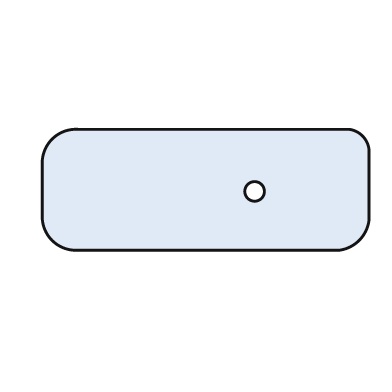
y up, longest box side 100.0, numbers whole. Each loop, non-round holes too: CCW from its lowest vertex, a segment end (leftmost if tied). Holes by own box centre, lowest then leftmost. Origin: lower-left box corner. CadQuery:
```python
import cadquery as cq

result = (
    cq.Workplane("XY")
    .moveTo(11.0, 0.0)
    .lineTo(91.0, 0.0)
    .threePointArc((97.0, 3.0), (100.0, 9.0))
    .lineTo(100.0, 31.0)
    .threePointArc((98.0, 35.0), (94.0, 37.0))
    .lineTo(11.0, 37.0)
    .threePointArc((3.0, 34.0), (0.0, 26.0))
    .lineTo(0.0, 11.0)
    .threePointArc((3.0, 3.0), (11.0, 0.0))
    .close()
    .moveTo(65.0, 18.0)
    .circle(3.0)
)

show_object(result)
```